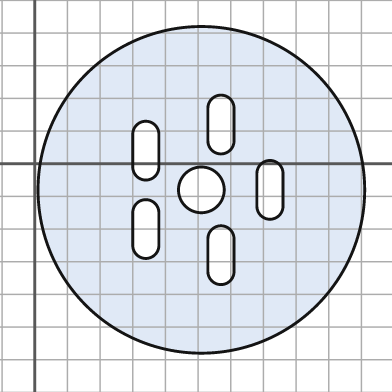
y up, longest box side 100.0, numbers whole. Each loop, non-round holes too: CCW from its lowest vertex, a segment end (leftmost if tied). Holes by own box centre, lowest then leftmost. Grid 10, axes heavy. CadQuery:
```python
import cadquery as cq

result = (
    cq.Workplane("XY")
    .moveTo(51.0, -8.0)
    .circle(50.0)
    .moveTo(53.0, -33.0)
    .threePointArc((57.0, -37.0), (61.0, -33.0))
    .lineTo(61.0, -23.0)
    .threePointArc((57.0, -19.0), (53.0, -23.0))
    .close()
    .moveTo(30.0, -25.0)
    .threePointArc((34.0, -29.0), (38.0, -25.0))
    .lineTo(38.0, -15.0)
    .threePointArc((34.0, -11.0), (30.0, -15.0))
    .close()
    .moveTo(51.0, -8.0)
    .circle(7.0)
    .moveTo(68.0, -13.0)
    .threePointArc((72.0, -17.0), (76.0, -13.0))
    .lineTo(76.0, -3.0)
    .threePointArc((72.0, 1.0), (68.0, -3.0))
    .close()
    .moveTo(30.0, -1.0)
    .threePointArc((34.0, -5.0), (38.0, -1.0))
    .lineTo(38.0, 9.0)
    .threePointArc((34.0, 13.0), (30.0, 9.0))
    .close()
    .moveTo(53.0, 7.0)
    .threePointArc((57.0, 3.0), (61.0, 7.0))
    .lineTo(61.0, 17.0)
    .threePointArc((57.0, 21.0), (53.0, 17.0))
    .close()
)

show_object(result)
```